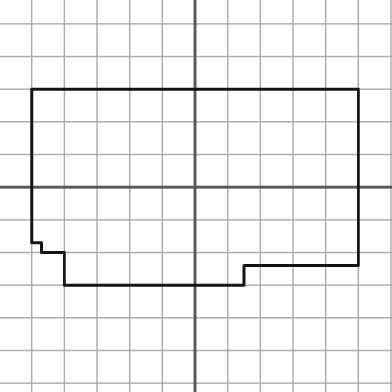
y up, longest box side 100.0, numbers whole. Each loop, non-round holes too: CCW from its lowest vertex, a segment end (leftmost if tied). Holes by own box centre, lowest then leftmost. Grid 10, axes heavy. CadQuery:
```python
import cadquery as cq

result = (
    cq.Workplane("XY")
    .moveTo(-40.0, -30.0)
    .lineTo(15.0, -30.0)
    .lineTo(15.0, -24.0)
    .lineTo(50.0, -24.0)
    .lineTo(50.0, 30.0)
    .lineTo(-50.0, 30.0)
    .lineTo(-50.0, -17.0)
    .lineTo(-47.0, -17.0)
    .lineTo(-47.0, -20.0)
    .lineTo(-40.0, -20.0)
    .close()
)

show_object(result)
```